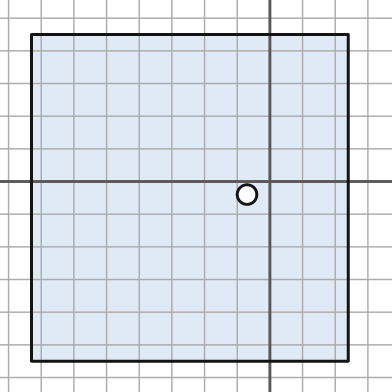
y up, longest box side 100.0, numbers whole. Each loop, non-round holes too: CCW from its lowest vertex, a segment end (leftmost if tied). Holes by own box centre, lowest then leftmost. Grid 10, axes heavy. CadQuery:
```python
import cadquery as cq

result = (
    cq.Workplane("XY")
    .moveTo(-73.0, -55.0)
    .lineTo(24.0, -55.0)
    .lineTo(24.0, 45.0)
    .lineTo(-73.0, 45.0)
    .close()
    .moveTo(-7.0, -4.0)
    .circle(3.0)
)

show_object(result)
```